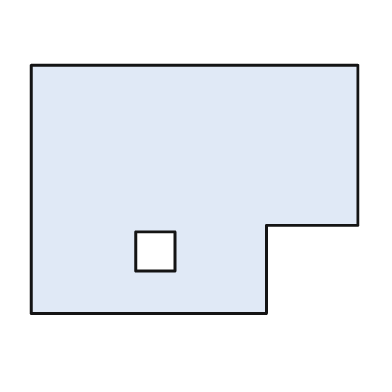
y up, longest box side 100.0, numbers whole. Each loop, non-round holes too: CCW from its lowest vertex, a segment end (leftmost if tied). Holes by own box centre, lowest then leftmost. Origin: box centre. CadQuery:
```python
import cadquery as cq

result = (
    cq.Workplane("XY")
    .moveTo(-50.0, -38.0)
    .lineTo(22.0, -38.0)
    .lineTo(22.0, -11.0)
    .lineTo(50.0, -11.0)
    .lineTo(50.0, 38.0)
    .lineTo(-50.0, 38.0)
    .close()
    .moveTo(-18.0, -25.0)
    .lineTo(-6.0, -25.0)
    .lineTo(-6.0, -13.0)
    .lineTo(-18.0, -13.0)
    .close()
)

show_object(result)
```